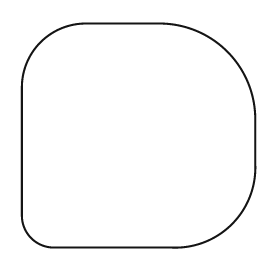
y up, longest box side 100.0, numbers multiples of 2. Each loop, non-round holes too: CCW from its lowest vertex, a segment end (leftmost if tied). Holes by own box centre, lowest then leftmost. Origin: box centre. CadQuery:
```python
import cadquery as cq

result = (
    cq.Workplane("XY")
    .moveTo(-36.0, -48.0)
    .lineTo(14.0, -48.0)
    .threePointArc((40.0, -38.0), (50.0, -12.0))
    .lineTo(50.0, 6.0)
    .threePointArc((38.0, 36.0), (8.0, 48.0))
    .lineTo(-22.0, 48.0)
    .threePointArc((-42.0, 40.0), (-50.0, 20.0))
    .lineTo(-50.0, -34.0)
    .threePointArc((-46.0, -44.0), (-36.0, -48.0))
    .close()
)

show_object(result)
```